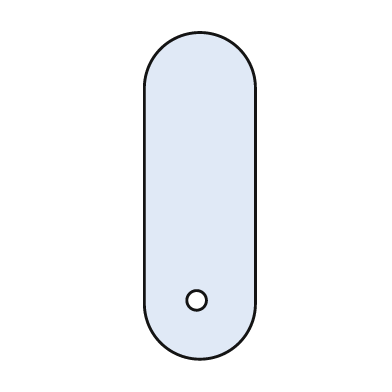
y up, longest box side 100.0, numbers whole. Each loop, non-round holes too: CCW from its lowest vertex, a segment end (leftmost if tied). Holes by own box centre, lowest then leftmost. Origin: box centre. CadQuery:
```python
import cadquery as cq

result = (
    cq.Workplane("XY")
    .moveTo(-17.0, -33.0)
    .threePointArc((0.0, -50.0), (17.0, -33.0))
    .lineTo(17.0, 33.0)
    .threePointArc((0.0, 50.0), (-17.0, 33.0))
    .close()
    .moveTo(-1.0, -32.0)
    .circle(3.0)
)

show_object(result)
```